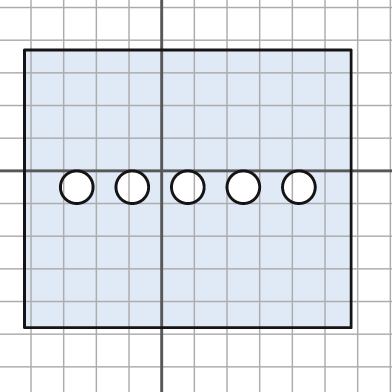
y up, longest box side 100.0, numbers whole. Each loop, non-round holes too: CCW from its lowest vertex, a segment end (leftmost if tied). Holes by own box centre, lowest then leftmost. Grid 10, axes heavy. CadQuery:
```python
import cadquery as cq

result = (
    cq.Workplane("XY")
    .moveTo(-42.0, -48.0)
    .lineTo(58.0, -48.0)
    .lineTo(58.0, 37.0)
    .lineTo(-42.0, 37.0)
    .close()
    .moveTo(-26.0, -5.0)
    .circle(5.0)
    .moveTo(-9.0, -5.0)
    .circle(5.0)
    .moveTo(8.0, -5.0)
    .circle(5.0)
    .moveTo(25.0, -5.0)
    .circle(5.0)
    .moveTo(42.0, -5.0)
    .circle(5.0)
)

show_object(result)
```